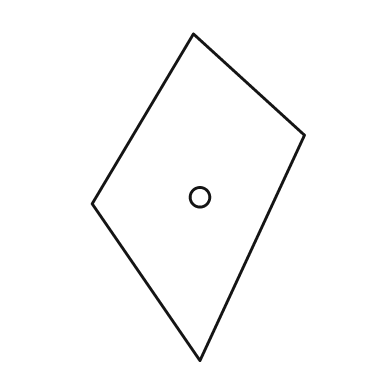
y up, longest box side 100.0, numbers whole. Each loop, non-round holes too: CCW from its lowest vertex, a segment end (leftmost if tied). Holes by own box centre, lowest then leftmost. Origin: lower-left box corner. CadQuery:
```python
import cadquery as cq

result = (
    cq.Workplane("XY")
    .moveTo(33.0, 0.0)
    .lineTo(65.0, 69.0)
    .lineTo(31.0, 100.0)
    .lineTo(0.0, 48.0)
    .close()
    .moveTo(33.0, 50.0)
    .circle(3.0)
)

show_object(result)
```